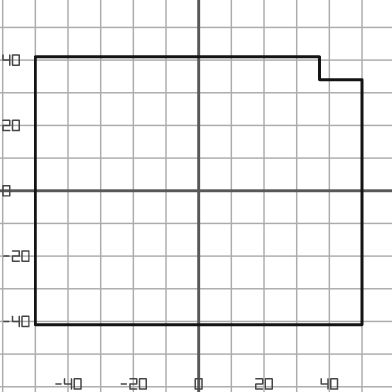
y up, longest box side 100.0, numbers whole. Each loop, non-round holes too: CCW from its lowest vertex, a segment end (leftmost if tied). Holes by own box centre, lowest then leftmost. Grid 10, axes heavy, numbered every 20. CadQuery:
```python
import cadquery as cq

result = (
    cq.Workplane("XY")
    .moveTo(-50.0, -41.0)
    .lineTo(50.0, -41.0)
    .lineTo(50.0, 34.0)
    .lineTo(37.0, 34.0)
    .lineTo(37.0, 41.0)
    .lineTo(-50.0, 41.0)
    .close()
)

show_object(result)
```